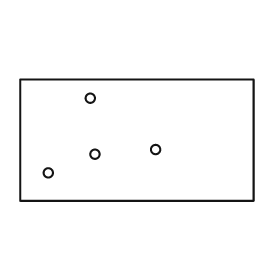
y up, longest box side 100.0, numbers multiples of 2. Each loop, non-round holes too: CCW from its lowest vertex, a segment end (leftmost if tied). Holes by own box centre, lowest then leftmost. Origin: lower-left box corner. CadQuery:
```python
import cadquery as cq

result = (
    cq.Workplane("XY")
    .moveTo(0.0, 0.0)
    .lineTo(100.0, 0.0)
    .lineTo(100.0, 52.0)
    .lineTo(0.0, 52.0)
    .close()
    .moveTo(12.0, 12.0)
    .circle(2.0)
    .moveTo(32.0, 20.0)
    .circle(2.0)
    .moveTo(58.0, 22.0)
    .circle(2.0)
    .moveTo(30.0, 44.0)
    .circle(2.0)
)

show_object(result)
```